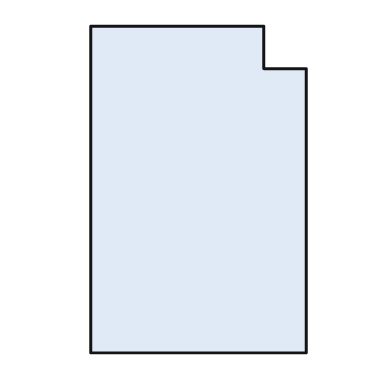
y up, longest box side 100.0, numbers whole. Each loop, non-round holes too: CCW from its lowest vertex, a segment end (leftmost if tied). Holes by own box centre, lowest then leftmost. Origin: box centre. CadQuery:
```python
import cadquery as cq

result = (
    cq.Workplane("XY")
    .moveTo(-33.0, -50.0)
    .lineTo(33.0, -50.0)
    .lineTo(33.0, 37.0)
    .lineTo(20.0, 37.0)
    .lineTo(20.0, 50.0)
    .lineTo(-33.0, 50.0)
    .close()
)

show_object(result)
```